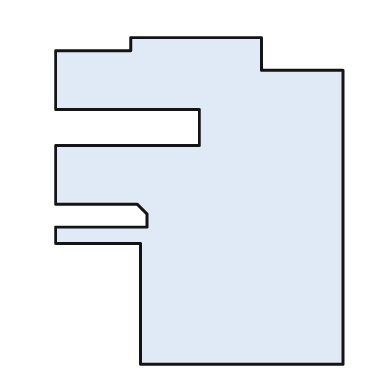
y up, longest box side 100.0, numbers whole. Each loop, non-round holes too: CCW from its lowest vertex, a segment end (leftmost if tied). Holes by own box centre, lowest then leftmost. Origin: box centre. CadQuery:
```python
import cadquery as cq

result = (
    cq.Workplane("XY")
    .moveTo(-18.0, -50.0)
    .lineTo(44.0, -50.0)
    .lineTo(44.0, 40.0)
    .lineTo(19.0, 40.0)
    .lineTo(19.0, 50.0)
    .lineTo(-21.0, 50.0)
    .lineTo(-21.0, 46.0)
    .lineTo(-44.0, 46.0)
    .lineTo(-44.0, 28.0)
    .lineTo(0.0, 28.0)
    .lineTo(0.0, 17.0)
    .lineTo(-44.0, 17.0)
    .lineTo(-44.0, -1.0)
    .lineTo(-19.0, -1.0)
    .lineTo(-16.0, -4.0)
    .lineTo(-16.0, -8.0)
    .lineTo(-44.0, -8.0)
    .lineTo(-44.0, -13.0)
    .lineTo(-18.0, -13.0)
    .close()
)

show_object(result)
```